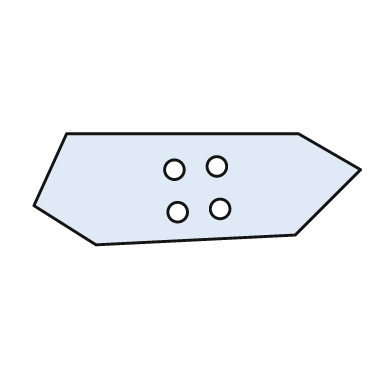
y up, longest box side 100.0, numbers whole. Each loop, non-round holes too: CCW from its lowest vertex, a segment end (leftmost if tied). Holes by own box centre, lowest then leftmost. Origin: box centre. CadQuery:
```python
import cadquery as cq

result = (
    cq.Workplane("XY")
    .moveTo(-31.0, -17.0)
    .lineTo(30.0, -14.0)
    .lineTo(50.0, 6.0)
    .lineTo(31.0, 17.0)
    .lineTo(-40.0, 17.0)
    .lineTo(-50.0, -5.0)
    .close()
    .moveTo(-6.0, -7.0)
    .circle(3.0)
    .moveTo(7.0, -6.0)
    .circle(3.0)
    .moveTo(-7.0, 6.0)
    .circle(3.0)
    .moveTo(6.0, 7.0)
    .circle(3.0)
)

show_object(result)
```